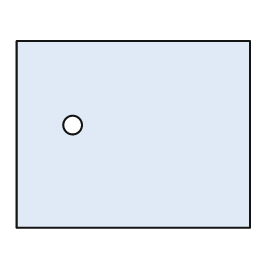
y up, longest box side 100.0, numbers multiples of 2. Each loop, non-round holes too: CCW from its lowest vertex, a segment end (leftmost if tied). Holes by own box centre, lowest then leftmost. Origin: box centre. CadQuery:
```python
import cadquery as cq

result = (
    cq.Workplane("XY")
    .moveTo(-50.0, -40.0)
    .lineTo(50.0, -40.0)
    .lineTo(50.0, 40.0)
    .lineTo(-50.0, 40.0)
    .close()
    .moveTo(-26.0, 4.0)
    .circle(4.0)
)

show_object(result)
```